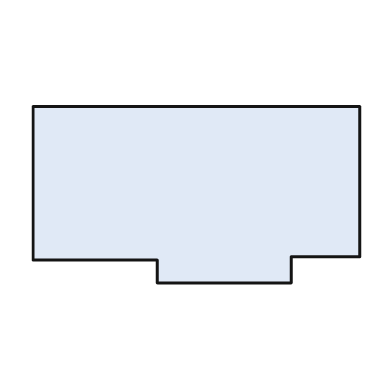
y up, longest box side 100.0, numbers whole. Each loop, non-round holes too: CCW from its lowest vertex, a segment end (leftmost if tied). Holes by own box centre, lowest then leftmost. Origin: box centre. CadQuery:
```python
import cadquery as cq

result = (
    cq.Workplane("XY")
    .moveTo(-12.0, -27.0)
    .lineTo(29.0, -27.0)
    .lineTo(29.0, -19.0)
    .lineTo(50.0, -19.0)
    .lineTo(50.0, 27.0)
    .lineTo(-50.0, 27.0)
    .lineTo(-50.0, -20.0)
    .lineTo(-12.0, -20.0)
    .close()
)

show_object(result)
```